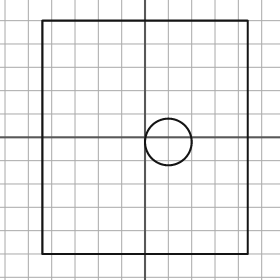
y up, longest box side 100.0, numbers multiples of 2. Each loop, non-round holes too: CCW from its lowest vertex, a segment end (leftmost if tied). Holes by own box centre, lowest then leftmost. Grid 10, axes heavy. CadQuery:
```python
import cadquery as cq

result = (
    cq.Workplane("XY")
    .moveTo(-44.0, -50.0)
    .lineTo(44.0, -50.0)
    .lineTo(44.0, 50.0)
    .lineTo(-44.0, 50.0)
    .close()
    .moveTo(10.0, -2.0)
    .circle(10.0)
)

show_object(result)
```